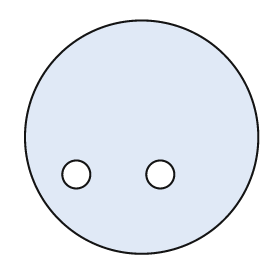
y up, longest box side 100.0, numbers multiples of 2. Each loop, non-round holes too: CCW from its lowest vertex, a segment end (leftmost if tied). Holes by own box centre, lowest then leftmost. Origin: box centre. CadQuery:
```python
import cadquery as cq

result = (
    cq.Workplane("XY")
    .moveTo(0.0, 0.0)
    .circle(50.0)
    .moveTo(-28.0, -16.0)
    .circle(6.0)
    .moveTo(8.0, -16.0)
    .circle(6.0)
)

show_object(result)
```